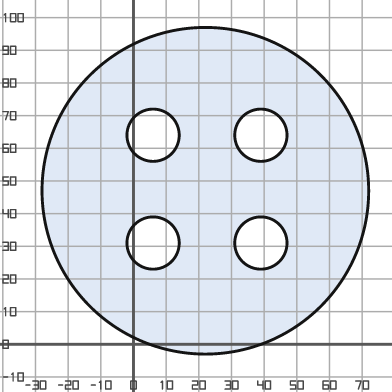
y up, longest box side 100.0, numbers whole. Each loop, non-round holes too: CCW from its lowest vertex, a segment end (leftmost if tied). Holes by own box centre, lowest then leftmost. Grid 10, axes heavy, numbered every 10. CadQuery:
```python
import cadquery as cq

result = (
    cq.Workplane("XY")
    .moveTo(22.0, 47.0)
    .circle(50.0)
    .moveTo(6.0, 31.0)
    .circle(8.0)
    .moveTo(39.0, 31.0)
    .circle(8.0)
    .moveTo(6.0, 64.0)
    .circle(8.0)
    .moveTo(39.0, 64.0)
    .circle(8.0)
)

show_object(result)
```